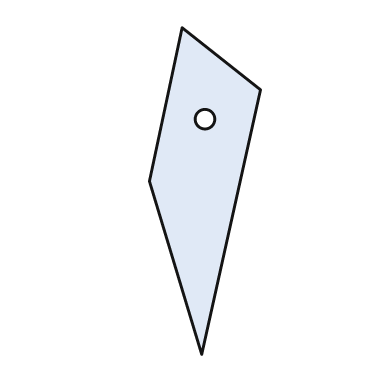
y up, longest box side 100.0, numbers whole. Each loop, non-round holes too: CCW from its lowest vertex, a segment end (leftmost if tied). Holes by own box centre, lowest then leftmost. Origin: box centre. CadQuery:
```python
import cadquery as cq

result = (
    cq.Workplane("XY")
    .moveTo(-1.0, -50.0)
    .lineTo(17.0, 31.0)
    .lineTo(-7.0, 50.0)
    .lineTo(-17.0, 3.0)
    .close()
    .moveTo(0.0, 22.0)
    .circle(3.0)
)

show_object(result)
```